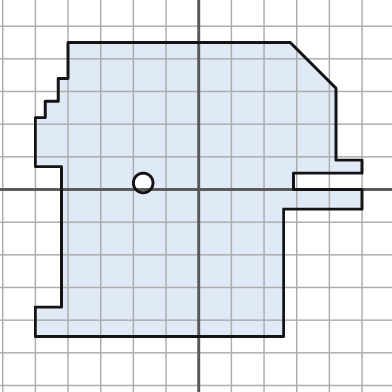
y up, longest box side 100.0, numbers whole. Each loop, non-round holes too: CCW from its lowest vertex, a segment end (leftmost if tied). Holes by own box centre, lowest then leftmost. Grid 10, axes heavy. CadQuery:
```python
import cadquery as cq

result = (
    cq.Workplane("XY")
    .moveTo(-50.0, -45.0)
    .lineTo(26.0, -45.0)
    .lineTo(26.0, -6.0)
    .lineTo(50.0, -6.0)
    .lineTo(50.0, 0.0)
    .lineTo(29.0, 0.0)
    .lineTo(29.0, 5.0)
    .lineTo(50.0, 5.0)
    .lineTo(50.0, 9.0)
    .lineTo(42.0, 9.0)
    .lineTo(42.0, 31.0)
    .lineTo(28.0, 45.0)
    .lineTo(-40.0, 45.0)
    .lineTo(-40.0, 34.0)
    .lineTo(-43.0, 34.0)
    .lineTo(-43.0, 27.0)
    .lineTo(-47.0, 27.0)
    .lineTo(-47.0, 22.0)
    .lineTo(-50.0, 22.0)
    .lineTo(-50.0, 7.0)
    .lineTo(-42.0, 7.0)
    .lineTo(-42.0, -36.0)
    .lineTo(-50.0, -36.0)
    .close()
    .moveTo(-17.0, 2.0)
    .circle(3.0)
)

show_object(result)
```